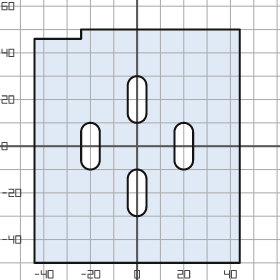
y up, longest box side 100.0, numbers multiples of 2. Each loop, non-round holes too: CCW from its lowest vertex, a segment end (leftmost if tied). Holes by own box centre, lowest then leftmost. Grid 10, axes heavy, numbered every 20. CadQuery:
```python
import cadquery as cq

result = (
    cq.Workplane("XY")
    .moveTo(-44.0, -50.0)
    .lineTo(44.0, -50.0)
    .lineTo(44.0, 50.0)
    .lineTo(-24.0, 50.0)
    .lineTo(-24.0, 46.0)
    .lineTo(-44.0, 46.0)
    .close()
    .moveTo(-4.0, -26.0)
    .threePointArc((0.0, -30.0), (4.0, -26.0))
    .lineTo(4.0, -14.0)
    .threePointArc((0.0, -10.0), (-4.0, -14.0))
    .close()
    .moveTo(-24.0, -6.0)
    .threePointArc((-20.0, -10.0), (-16.0, -6.0))
    .lineTo(-16.0, 6.0)
    .threePointArc((-20.0, 10.0), (-24.0, 6.0))
    .close()
    .moveTo(16.0, -6.0)
    .threePointArc((20.0, -10.0), (24.0, -6.0))
    .lineTo(24.0, 6.0)
    .threePointArc((20.0, 10.0), (16.0, 6.0))
    .close()
    .moveTo(-4.0, 14.0)
    .threePointArc((0.0, 10.0), (4.0, 14.0))
    .lineTo(4.0, 26.0)
    .threePointArc((0.0, 30.0), (-4.0, 26.0))
    .close()
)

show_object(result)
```